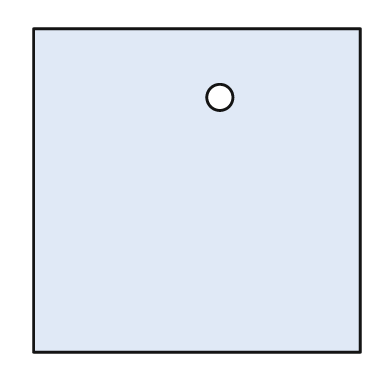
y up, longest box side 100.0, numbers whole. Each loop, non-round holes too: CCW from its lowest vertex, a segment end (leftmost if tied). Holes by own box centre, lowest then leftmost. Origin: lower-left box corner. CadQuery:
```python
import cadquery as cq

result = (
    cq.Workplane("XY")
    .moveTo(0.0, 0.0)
    .lineTo(100.0, 0.0)
    .lineTo(100.0, 99.0)
    .lineTo(0.0, 99.0)
    .close()
    .moveTo(57.0, 78.0)
    .circle(4.0)
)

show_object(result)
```